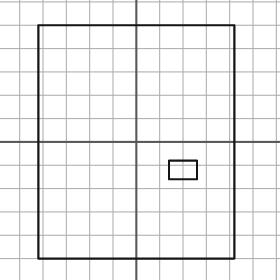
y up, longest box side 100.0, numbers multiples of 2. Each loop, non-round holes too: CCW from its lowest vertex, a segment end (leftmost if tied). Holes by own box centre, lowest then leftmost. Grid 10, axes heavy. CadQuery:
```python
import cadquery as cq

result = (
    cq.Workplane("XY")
    .moveTo(-42.0, -50.0)
    .lineTo(42.0, -50.0)
    .lineTo(42.0, 50.0)
    .lineTo(-42.0, 50.0)
    .close()
    .moveTo(14.0, -16.0)
    .lineTo(26.0, -16.0)
    .lineTo(26.0, -8.0)
    .lineTo(14.0, -8.0)
    .close()
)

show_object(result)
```